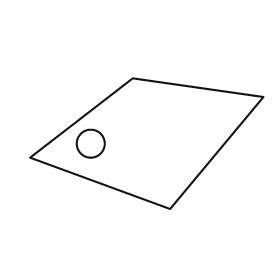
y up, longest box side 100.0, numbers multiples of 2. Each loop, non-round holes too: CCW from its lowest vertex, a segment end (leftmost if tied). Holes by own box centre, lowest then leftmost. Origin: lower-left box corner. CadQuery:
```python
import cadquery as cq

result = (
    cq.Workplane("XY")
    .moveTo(60.0, 0.0)
    .lineTo(100.0, 48.0)
    .lineTo(44.0, 56.0)
    .lineTo(0.0, 22.0)
    .close()
    .moveTo(26.0, 28.0)
    .circle(6.0)
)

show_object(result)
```